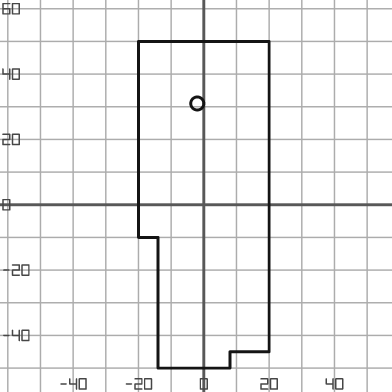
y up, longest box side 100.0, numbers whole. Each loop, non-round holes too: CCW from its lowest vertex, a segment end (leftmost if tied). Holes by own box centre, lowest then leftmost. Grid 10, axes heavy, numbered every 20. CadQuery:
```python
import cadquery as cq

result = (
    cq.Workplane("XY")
    .moveTo(-14.0, -50.0)
    .lineTo(8.0, -50.0)
    .lineTo(8.0, -45.0)
    .lineTo(20.0, -45.0)
    .lineTo(20.0, 50.0)
    .lineTo(-20.0, 50.0)
    .lineTo(-20.0, -10.0)
    .lineTo(-14.0, -10.0)
    .close()
    .moveTo(-2.0, 31.0)
    .circle(2.0)
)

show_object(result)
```